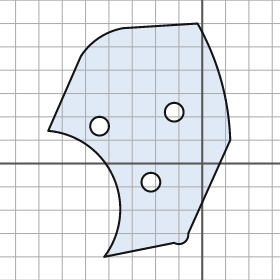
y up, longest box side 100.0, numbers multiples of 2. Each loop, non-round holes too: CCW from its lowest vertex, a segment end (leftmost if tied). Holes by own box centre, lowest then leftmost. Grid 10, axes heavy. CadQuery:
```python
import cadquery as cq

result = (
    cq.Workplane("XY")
    .moveTo(-42.0, -40.0)
    .lineTo(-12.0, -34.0)
    .threePointArc((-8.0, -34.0), (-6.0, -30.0))
    .lineTo(12.0, 10.0)
    .threePointArc((8.0, 36.0), (-2.0, 60.0))
    .lineTo(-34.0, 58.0)
    .threePointArc((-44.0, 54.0), (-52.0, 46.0))
    .lineTo(-66.0, 14.0)
    .threePointArc((-38.0, -6.0), (-42.0, -40.0))
    .close()
    .moveTo(-22.0, -8.0)
    .circle(4.0)
    .moveTo(-44.0, 16.0)
    .circle(4.0)
    .moveTo(-12.0, 22.0)
    .circle(4.0)
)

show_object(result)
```